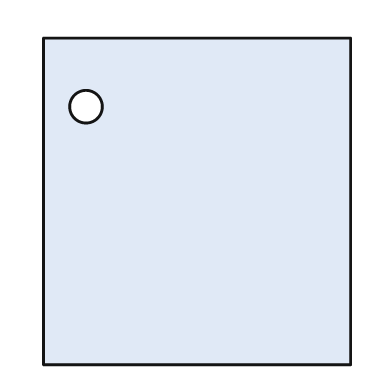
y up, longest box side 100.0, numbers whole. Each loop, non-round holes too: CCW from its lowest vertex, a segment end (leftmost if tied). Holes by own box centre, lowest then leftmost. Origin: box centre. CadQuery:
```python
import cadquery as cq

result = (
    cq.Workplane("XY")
    .moveTo(-47.0, -50.0)
    .lineTo(47.0, -50.0)
    .lineTo(47.0, 50.0)
    .lineTo(-47.0, 50.0)
    .close()
    .moveTo(-34.0, 29.0)
    .circle(5.0)
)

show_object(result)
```